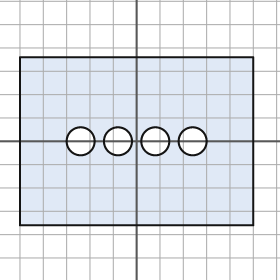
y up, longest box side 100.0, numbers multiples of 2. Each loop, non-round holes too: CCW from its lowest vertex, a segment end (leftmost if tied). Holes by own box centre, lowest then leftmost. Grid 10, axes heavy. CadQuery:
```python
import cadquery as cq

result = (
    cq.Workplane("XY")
    .moveTo(-50.0, -36.0)
    .lineTo(50.0, -36.0)
    .lineTo(50.0, 36.0)
    .lineTo(-50.0, 36.0)
    .close()
    .moveTo(-24.0, 0.0)
    .circle(6.0)
    .moveTo(-8.0, 0.0)
    .circle(6.0)
    .moveTo(8.0, 0.0)
    .circle(6.0)
    .moveTo(24.0, 0.0)
    .circle(6.0)
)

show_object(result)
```